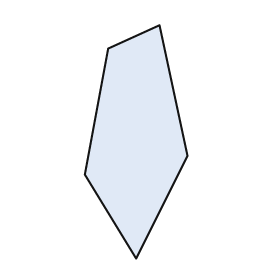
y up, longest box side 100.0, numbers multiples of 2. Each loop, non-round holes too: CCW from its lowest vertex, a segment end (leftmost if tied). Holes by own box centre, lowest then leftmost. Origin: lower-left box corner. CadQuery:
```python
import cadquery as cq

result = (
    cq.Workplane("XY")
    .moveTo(22.0, 0.0)
    .lineTo(44.0, 44.0)
    .lineTo(32.0, 100.0)
    .lineTo(10.0, 90.0)
    .lineTo(0.0, 36.0)
    .close()
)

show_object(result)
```